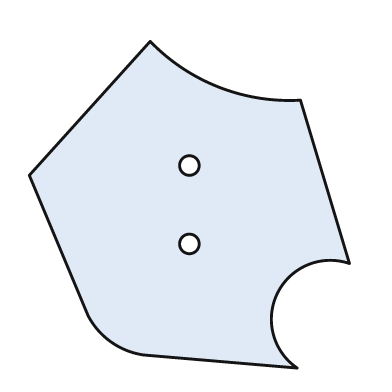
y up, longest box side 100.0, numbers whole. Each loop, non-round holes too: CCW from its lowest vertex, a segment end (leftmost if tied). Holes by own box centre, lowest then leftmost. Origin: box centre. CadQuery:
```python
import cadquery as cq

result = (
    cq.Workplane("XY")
    .moveTo(33.0, -50.0)
    .threePointArc((27.0, -27.0), (49.0, -18.0))
    .lineTo(34.0, 32.0)
    .threePointArc((9.0, 36.0), (-12.0, 50.0))
    .lineTo(-49.0, 9.0)
    .lineTo(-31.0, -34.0)
    .threePointArc((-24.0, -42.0), (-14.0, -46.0))
    .close()
    .moveTo(0.0, -12.0)
    .circle(3.0)
    .moveTo(0.0, 12.0)
    .circle(3.0)
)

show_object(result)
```